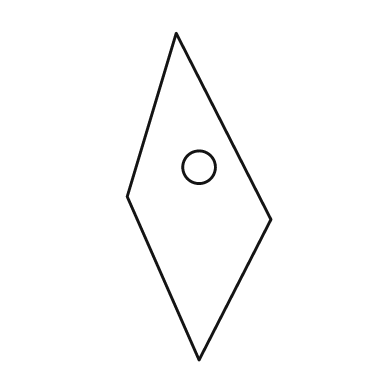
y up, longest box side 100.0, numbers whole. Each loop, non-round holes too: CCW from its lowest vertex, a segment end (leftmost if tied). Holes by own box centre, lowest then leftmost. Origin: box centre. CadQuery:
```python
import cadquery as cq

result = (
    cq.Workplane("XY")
    .moveTo(0.0, -50.0)
    .lineTo(22.0, -7.0)
    .lineTo(-7.0, 50.0)
    .lineTo(-22.0, 0.0)
    .close()
    .moveTo(0.0, 9.0)
    .circle(5.0)
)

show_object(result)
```